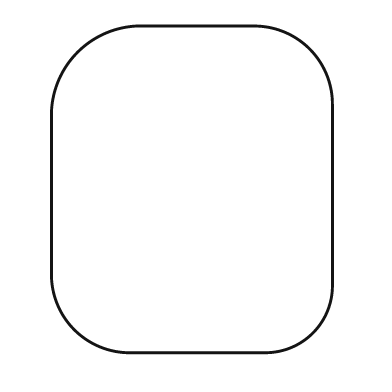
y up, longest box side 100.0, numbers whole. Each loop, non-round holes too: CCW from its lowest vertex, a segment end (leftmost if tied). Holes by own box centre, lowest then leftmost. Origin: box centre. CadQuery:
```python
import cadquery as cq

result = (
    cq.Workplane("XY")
    .moveTo(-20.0, -50.0)
    .lineTo(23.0, -50.0)
    .threePointArc((37.0, -44.0), (43.0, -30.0))
    .lineTo(43.0, 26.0)
    .threePointArc((36.0, 43.0), (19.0, 50.0))
    .lineTo(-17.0, 50.0)
    .threePointArc((-35.0, 42.0), (-43.0, 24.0))
    .lineTo(-43.0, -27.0)
    .threePointArc((-36.0, -43.0), (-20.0, -50.0))
    .close()
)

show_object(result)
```